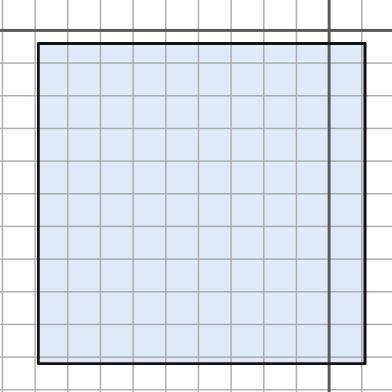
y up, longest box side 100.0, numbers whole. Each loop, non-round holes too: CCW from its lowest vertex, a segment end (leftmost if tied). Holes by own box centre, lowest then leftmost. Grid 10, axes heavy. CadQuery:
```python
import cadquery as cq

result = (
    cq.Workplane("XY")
    .moveTo(-89.0, -102.0)
    .lineTo(11.0, -102.0)
    .lineTo(11.0, -4.0)
    .lineTo(-89.0, -4.0)
    .close()
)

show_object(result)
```